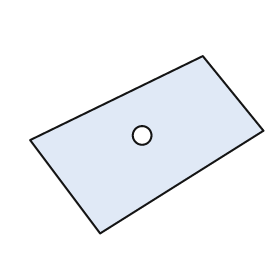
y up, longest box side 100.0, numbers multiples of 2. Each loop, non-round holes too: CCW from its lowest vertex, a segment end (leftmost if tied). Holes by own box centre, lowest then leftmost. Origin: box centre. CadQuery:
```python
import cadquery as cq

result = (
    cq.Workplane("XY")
    .moveTo(-20.0, -38.0)
    .lineTo(50.0, 6.0)
    .lineTo(24.0, 38.0)
    .lineTo(-50.0, 2.0)
    .close()
    .moveTo(-2.0, 4.0)
    .circle(4.0)
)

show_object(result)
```